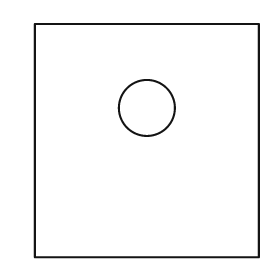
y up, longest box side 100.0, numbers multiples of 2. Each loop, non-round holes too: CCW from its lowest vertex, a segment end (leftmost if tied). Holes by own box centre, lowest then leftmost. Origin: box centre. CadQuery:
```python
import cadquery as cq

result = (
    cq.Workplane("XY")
    .moveTo(-48.0, -50.0)
    .lineTo(48.0, -50.0)
    .lineTo(48.0, 50.0)
    .lineTo(-48.0, 50.0)
    .close()
    .moveTo(0.0, 14.0)
    .circle(12.0)
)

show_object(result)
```